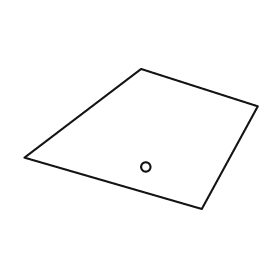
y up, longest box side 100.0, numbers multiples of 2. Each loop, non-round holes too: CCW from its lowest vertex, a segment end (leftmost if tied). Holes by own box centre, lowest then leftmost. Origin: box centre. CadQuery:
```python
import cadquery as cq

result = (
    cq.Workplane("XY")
    .moveTo(26.0, -30.0)
    .lineTo(50.0, 14.0)
    .lineTo(0.0, 30.0)
    .lineTo(-50.0, -8.0)
    .close()
    .moveTo(2.0, -12.0)
    .circle(2.0)
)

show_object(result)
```